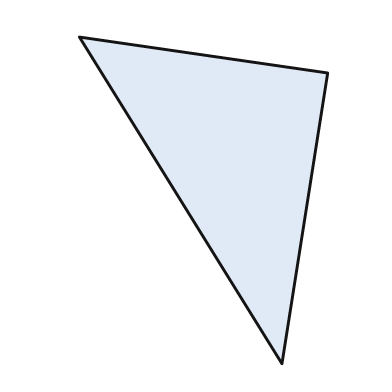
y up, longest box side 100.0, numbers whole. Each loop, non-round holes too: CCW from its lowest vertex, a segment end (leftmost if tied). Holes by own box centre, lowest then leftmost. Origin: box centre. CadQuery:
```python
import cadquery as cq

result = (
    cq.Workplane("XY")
    .moveTo(24.0, -50.0)
    .lineTo(38.0, 39.0)
    .lineTo(-38.0, 50.0)
    .close()
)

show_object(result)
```